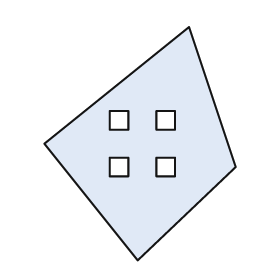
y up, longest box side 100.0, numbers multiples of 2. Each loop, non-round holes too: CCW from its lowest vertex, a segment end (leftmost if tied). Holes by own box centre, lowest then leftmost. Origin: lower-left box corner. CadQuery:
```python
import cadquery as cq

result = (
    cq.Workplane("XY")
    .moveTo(40.0, 0.0)
    .lineTo(82.0, 40.0)
    .lineTo(62.0, 100.0)
    .lineTo(0.0, 50.0)
    .close()
    .moveTo(28.0, 36.0)
    .lineTo(36.0, 36.0)
    .lineTo(36.0, 44.0)
    .lineTo(28.0, 44.0)
    .close()
    .moveTo(48.0, 36.0)
    .lineTo(56.0, 36.0)
    .lineTo(56.0, 44.0)
    .lineTo(48.0, 44.0)
    .close()
    .moveTo(28.0, 56.0)
    .lineTo(36.0, 56.0)
    .lineTo(36.0, 64.0)
    .lineTo(28.0, 64.0)
    .close()
    .moveTo(48.0, 56.0)
    .lineTo(56.0, 56.0)
    .lineTo(56.0, 64.0)
    .lineTo(48.0, 64.0)
    .close()
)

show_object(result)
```